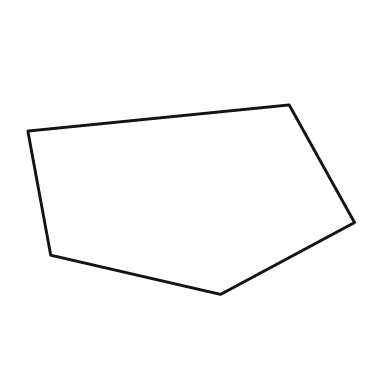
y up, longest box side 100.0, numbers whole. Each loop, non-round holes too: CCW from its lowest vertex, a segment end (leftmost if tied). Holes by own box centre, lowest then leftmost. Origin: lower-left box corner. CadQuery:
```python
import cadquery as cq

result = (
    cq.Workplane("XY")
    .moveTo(59.0, 0.0)
    .lineTo(100.0, 22.0)
    .lineTo(80.0, 58.0)
    .lineTo(0.0, 50.0)
    .lineTo(7.0, 12.0)
    .close()
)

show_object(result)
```